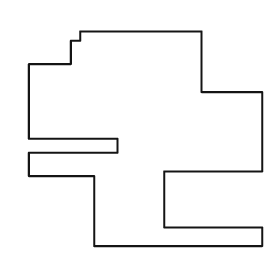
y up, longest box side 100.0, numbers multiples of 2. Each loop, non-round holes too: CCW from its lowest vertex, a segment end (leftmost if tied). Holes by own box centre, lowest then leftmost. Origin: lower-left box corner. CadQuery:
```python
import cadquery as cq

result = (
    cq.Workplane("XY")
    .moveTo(28.0, 0.0)
    .lineTo(100.0, 0.0)
    .lineTo(100.0, 8.0)
    .lineTo(58.0, 8.0)
    .lineTo(58.0, 32.0)
    .lineTo(100.0, 32.0)
    .lineTo(100.0, 66.0)
    .lineTo(74.0, 66.0)
    .lineTo(74.0, 92.0)
    .lineTo(22.0, 92.0)
    .lineTo(22.0, 88.0)
    .lineTo(18.0, 88.0)
    .lineTo(18.0, 78.0)
    .lineTo(0.0, 78.0)
    .lineTo(0.0, 46.0)
    .lineTo(38.0, 46.0)
    .lineTo(38.0, 40.0)
    .lineTo(0.0, 40.0)
    .lineTo(0.0, 30.0)
    .lineTo(28.0, 30.0)
    .close()
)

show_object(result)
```